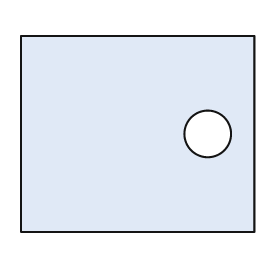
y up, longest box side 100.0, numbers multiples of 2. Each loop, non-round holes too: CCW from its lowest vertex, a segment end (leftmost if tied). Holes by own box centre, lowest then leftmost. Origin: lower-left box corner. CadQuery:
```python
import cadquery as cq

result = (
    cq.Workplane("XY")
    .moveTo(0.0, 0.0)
    .lineTo(100.0, 0.0)
    .lineTo(100.0, 84.0)
    .lineTo(0.0, 84.0)
    .close()
    .moveTo(80.0, 42.0)
    .circle(10.0)
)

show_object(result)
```